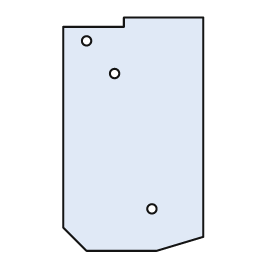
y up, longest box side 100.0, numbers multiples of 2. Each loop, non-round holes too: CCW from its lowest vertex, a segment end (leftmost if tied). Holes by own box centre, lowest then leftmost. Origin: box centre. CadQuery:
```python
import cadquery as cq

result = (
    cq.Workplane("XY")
    .moveTo(-20.0, -50.0)
    .lineTo(10.0, -50.0)
    .lineTo(30.0, -44.0)
    .lineTo(30.0, 50.0)
    .lineTo(-4.0, 50.0)
    .lineTo(-4.0, 46.0)
    .lineTo(-30.0, 46.0)
    .lineTo(-30.0, -40.0)
    .close()
    .moveTo(8.0, -32.0)
    .circle(2.0)
    .moveTo(-8.0, 26.0)
    .circle(2.0)
    .moveTo(-20.0, 40.0)
    .circle(2.0)
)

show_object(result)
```